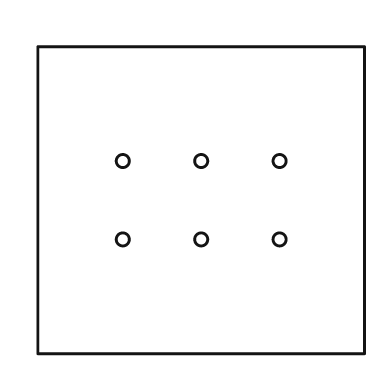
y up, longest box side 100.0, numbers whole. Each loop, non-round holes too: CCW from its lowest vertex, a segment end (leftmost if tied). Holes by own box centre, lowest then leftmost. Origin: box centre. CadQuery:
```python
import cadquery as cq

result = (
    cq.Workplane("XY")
    .moveTo(-50.0, -47.0)
    .lineTo(50.0, -47.0)
    .lineTo(50.0, 47.0)
    .lineTo(-50.0, 47.0)
    .close()
    .moveTo(-24.0, -12.0)
    .circle(2.0)
    .moveTo(0.0, -12.0)
    .circle(2.0)
    .moveTo(24.0, -12.0)
    .circle(2.0)
    .moveTo(-24.0, 12.0)
    .circle(2.0)
    .moveTo(0.0, 12.0)
    .circle(2.0)
    .moveTo(24.0, 12.0)
    .circle(2.0)
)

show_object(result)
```